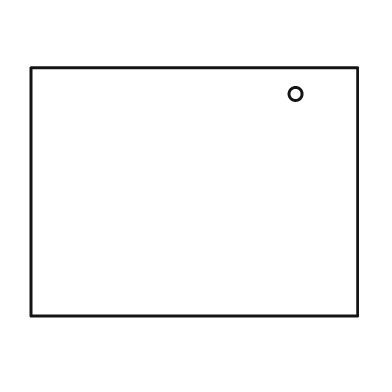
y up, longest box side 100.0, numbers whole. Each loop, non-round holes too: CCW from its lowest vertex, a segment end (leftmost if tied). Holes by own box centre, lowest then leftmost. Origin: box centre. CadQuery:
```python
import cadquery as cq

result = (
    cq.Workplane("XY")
    .moveTo(-50.0, -38.0)
    .lineTo(50.0, -38.0)
    .lineTo(50.0, 38.0)
    .lineTo(-50.0, 38.0)
    .close()
    .moveTo(31.0, 30.0)
    .circle(2.0)
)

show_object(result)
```